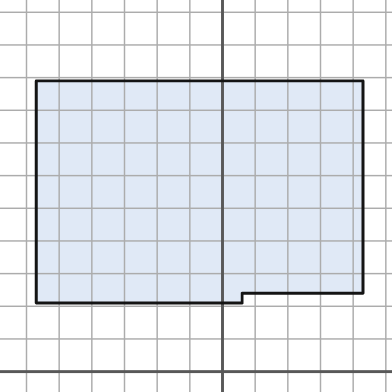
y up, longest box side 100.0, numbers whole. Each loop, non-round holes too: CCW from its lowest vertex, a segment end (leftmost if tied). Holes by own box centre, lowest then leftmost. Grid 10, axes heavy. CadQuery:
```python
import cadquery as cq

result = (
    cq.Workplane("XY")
    .moveTo(-57.0, 21.0)
    .lineTo(6.0, 21.0)
    .lineTo(6.0, 24.0)
    .lineTo(43.0, 24.0)
    .lineTo(43.0, 89.0)
    .lineTo(-57.0, 89.0)
    .close()
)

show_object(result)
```